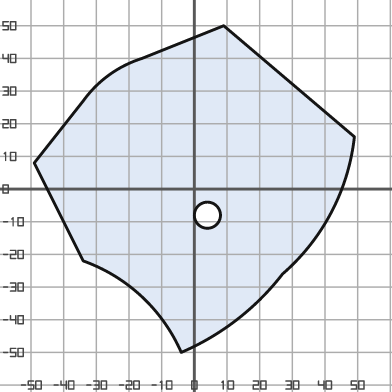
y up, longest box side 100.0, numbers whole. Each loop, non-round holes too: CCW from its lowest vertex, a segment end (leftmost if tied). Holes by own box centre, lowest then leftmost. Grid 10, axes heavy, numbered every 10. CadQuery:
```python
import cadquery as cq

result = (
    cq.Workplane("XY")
    .moveTo(-4.0, -50.0)
    .threePointArc((13.0, -40.0), (27.0, -26.0))
    .threePointArc((42.0, -7.0), (49.0, 16.0))
    .lineTo(9.0, 50.0)
    .lineTo(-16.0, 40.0)
    .threePointArc((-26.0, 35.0), (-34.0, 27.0))
    .lineTo(-49.0, 8.0)
    .lineTo(-34.0, -22.0)
    .threePointArc((-16.0, -33.0), (-4.0, -50.0))
    .close()
    .moveTo(4.0, -8.0)
    .circle(4.0)
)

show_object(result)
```